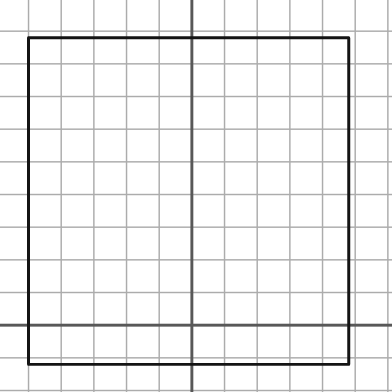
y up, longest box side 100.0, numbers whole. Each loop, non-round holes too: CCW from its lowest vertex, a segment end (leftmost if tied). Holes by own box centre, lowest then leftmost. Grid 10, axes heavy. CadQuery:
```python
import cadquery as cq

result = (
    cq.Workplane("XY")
    .moveTo(-50.0, -12.0)
    .lineTo(48.0, -12.0)
    .lineTo(48.0, 88.0)
    .lineTo(-50.0, 88.0)
    .close()
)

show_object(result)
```